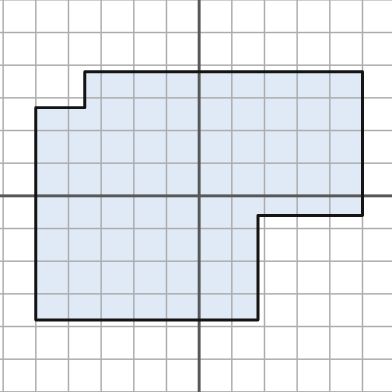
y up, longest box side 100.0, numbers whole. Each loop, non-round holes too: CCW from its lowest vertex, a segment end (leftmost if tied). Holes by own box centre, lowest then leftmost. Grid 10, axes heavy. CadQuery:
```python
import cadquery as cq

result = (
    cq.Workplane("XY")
    .moveTo(-50.0, -38.0)
    .lineTo(18.0, -38.0)
    .lineTo(18.0, -6.0)
    .lineTo(50.0, -6.0)
    .lineTo(50.0, 38.0)
    .lineTo(-35.0, 38.0)
    .lineTo(-35.0, 27.0)
    .lineTo(-50.0, 27.0)
    .close()
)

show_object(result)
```